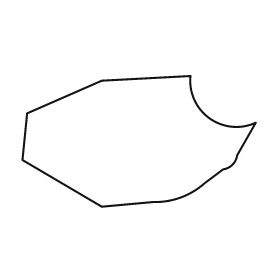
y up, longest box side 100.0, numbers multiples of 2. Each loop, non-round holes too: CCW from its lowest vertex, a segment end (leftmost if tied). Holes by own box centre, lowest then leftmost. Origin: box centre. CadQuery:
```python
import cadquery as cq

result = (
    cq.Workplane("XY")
    .moveTo(-16.0, -28.0)
    .lineTo(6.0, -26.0)
    .threePointArc((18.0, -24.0), (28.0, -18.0))
    .lineTo(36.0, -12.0)
    .threePointArc((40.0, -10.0), (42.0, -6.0))
    .lineTo(50.0, 8.0)
    .threePointArc((30.0, 10.0), (22.0, 28.0))
    .lineTo(-16.0, 26.0)
    .lineTo(-48.0, 12.0)
    .lineTo(-50.0, -8.0)
    .close()
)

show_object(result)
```